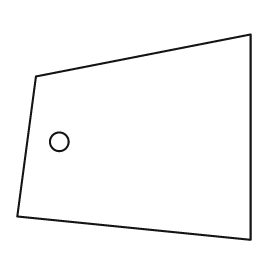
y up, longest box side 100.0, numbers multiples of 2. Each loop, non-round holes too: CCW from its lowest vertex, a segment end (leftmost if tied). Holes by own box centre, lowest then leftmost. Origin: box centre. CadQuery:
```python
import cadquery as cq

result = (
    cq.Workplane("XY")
    .moveTo(50.0, -44.0)
    .lineTo(50.0, 44.0)
    .lineTo(-42.0, 26.0)
    .lineTo(-50.0, -34.0)
    .close()
    .moveTo(-32.0, -2.0)
    .circle(4.0)
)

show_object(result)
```